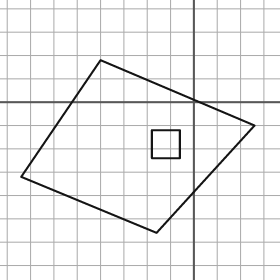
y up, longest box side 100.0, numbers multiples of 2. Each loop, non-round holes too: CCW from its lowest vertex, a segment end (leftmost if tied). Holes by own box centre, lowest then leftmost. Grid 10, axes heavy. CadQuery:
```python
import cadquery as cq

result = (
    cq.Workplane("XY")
    .moveTo(-16.0, -56.0)
    .lineTo(26.0, -10.0)
    .lineTo(-40.0, 18.0)
    .lineTo(-74.0, -32.0)
    .close()
    .moveTo(-18.0, -24.0)
    .lineTo(-6.0, -24.0)
    .lineTo(-6.0, -12.0)
    .lineTo(-18.0, -12.0)
    .close()
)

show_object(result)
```